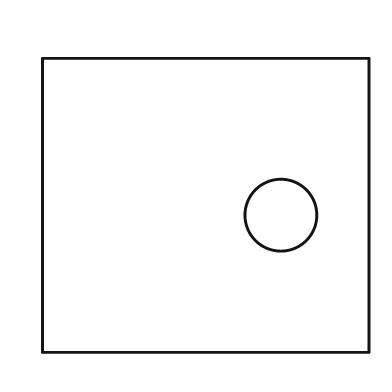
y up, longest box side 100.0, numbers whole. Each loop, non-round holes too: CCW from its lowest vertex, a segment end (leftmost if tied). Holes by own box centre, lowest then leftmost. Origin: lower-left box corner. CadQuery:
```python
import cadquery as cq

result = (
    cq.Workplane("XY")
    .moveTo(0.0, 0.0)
    .lineTo(100.0, 0.0)
    .lineTo(100.0, 90.0)
    .lineTo(0.0, 90.0)
    .close()
    .moveTo(73.0, 42.0)
    .circle(11.0)
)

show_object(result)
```